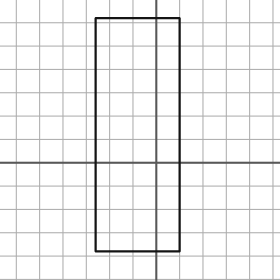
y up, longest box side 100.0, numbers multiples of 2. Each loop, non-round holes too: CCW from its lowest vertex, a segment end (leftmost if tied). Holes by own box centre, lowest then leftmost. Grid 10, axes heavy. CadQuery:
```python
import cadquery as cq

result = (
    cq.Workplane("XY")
    .moveTo(-26.0, -38.0)
    .lineTo(10.0, -38.0)
    .lineTo(10.0, 62.0)
    .lineTo(-26.0, 62.0)
    .close()
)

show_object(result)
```